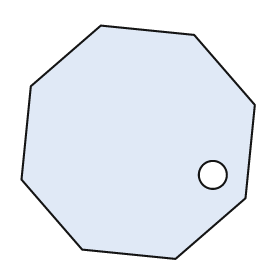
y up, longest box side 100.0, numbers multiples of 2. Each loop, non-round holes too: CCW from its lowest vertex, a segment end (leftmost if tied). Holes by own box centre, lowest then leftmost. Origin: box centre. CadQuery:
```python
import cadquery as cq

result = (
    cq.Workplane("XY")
    .moveTo(16.0, -50.0)
    .lineTo(46.0, -24.0)
    .lineTo(50.0, 16.0)
    .lineTo(24.0, 46.0)
    .lineTo(-16.0, 50.0)
    .lineTo(-46.0, 24.0)
    .lineTo(-50.0, -16.0)
    .lineTo(-24.0, -46.0)
    .close()
    .moveTo(32.0, -14.0)
    .circle(6.0)
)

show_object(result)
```